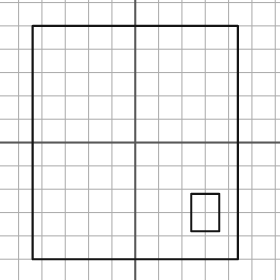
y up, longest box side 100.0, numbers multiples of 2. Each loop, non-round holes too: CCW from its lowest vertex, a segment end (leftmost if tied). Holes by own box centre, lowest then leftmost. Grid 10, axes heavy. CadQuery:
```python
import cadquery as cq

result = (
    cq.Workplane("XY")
    .moveTo(-44.0, -50.0)
    .lineTo(44.0, -50.0)
    .lineTo(44.0, 50.0)
    .lineTo(-44.0, 50.0)
    .close()
    .moveTo(24.0, -38.0)
    .lineTo(36.0, -38.0)
    .lineTo(36.0, -22.0)
    .lineTo(24.0, -22.0)
    .close()
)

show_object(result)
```